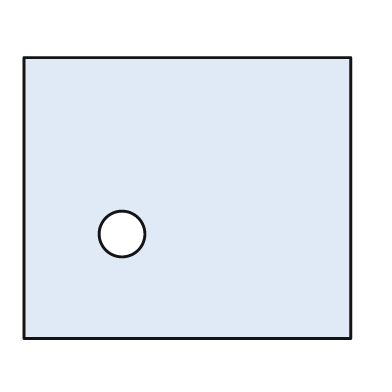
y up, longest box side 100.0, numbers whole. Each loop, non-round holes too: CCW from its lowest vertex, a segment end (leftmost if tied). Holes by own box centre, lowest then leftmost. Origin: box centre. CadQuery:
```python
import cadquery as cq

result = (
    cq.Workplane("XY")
    .moveTo(-50.0, -43.0)
    .lineTo(50.0, -43.0)
    .lineTo(50.0, 43.0)
    .lineTo(-50.0, 43.0)
    .close()
    .moveTo(-20.0, -11.0)
    .circle(7.0)
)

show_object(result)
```